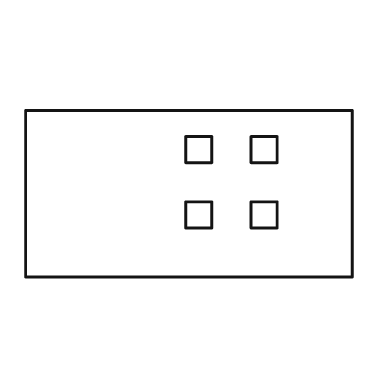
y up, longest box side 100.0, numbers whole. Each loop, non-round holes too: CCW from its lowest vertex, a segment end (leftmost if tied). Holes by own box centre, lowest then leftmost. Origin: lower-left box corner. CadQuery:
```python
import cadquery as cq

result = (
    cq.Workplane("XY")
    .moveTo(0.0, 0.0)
    .lineTo(100.0, 0.0)
    .lineTo(100.0, 51.0)
    .lineTo(0.0, 51.0)
    .close()
    .moveTo(49.0, 15.0)
    .lineTo(57.0, 15.0)
    .lineTo(57.0, 23.0)
    .lineTo(49.0, 23.0)
    .close()
    .moveTo(69.0, 15.0)
    .lineTo(77.0, 15.0)
    .lineTo(77.0, 23.0)
    .lineTo(69.0, 23.0)
    .close()
    .moveTo(49.0, 35.0)
    .lineTo(57.0, 35.0)
    .lineTo(57.0, 43.0)
    .lineTo(49.0, 43.0)
    .close()
    .moveTo(69.0, 35.0)
    .lineTo(77.0, 35.0)
    .lineTo(77.0, 43.0)
    .lineTo(69.0, 43.0)
    .close()
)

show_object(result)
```